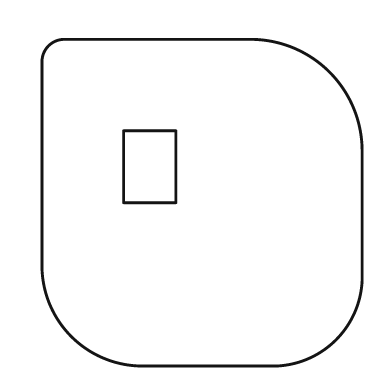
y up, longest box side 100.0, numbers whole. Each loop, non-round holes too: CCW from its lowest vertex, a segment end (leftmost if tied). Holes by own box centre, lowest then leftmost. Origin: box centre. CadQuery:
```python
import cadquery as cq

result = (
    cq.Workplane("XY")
    .moveTo(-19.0, -50.0)
    .lineTo(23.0, -50.0)
    .threePointArc((41.0, -42.0), (49.0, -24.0))
    .lineTo(49.0, 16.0)
    .threePointArc((39.0, 40.0), (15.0, 50.0))
    .lineTo(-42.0, 50.0)
    .threePointArc((-47.0, 48.0), (-49.0, 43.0))
    .lineTo(-49.0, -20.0)
    .threePointArc((-40.0, -41.0), (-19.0, -50.0))
    .close()
    .moveTo(-24.0, 0.0)
    .lineTo(-8.0, 0.0)
    .lineTo(-8.0, 22.0)
    .lineTo(-24.0, 22.0)
    .close()
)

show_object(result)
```